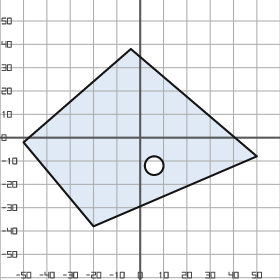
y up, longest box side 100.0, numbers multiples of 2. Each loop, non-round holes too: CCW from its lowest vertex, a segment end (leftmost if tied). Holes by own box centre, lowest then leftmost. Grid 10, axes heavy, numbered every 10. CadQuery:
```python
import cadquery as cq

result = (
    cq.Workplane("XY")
    .moveTo(-20.0, -38.0)
    .lineTo(50.0, -8.0)
    .lineTo(-4.0, 38.0)
    .lineTo(-50.0, -2.0)
    .close()
    .moveTo(6.0, -12.0)
    .circle(4.0)
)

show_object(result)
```